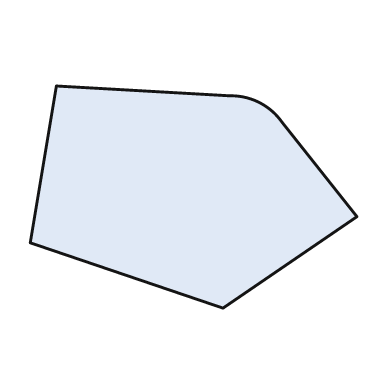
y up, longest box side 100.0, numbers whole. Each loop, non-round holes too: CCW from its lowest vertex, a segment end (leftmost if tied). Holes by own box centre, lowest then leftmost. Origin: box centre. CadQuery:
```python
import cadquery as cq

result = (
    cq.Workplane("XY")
    .moveTo(9.0, -34.0)
    .lineTo(50.0, -6.0)
    .lineTo(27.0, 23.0)
    .threePointArc((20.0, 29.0), (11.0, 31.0))
    .lineTo(-42.0, 34.0)
    .lineTo(-50.0, -14.0)
    .close()
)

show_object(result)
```